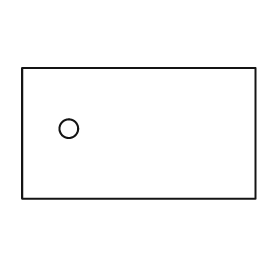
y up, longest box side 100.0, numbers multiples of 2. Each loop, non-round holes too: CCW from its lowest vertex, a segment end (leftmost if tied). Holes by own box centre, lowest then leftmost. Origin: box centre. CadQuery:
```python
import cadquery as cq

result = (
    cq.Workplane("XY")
    .moveTo(-50.0, -28.0)
    .lineTo(50.0, -28.0)
    .lineTo(50.0, 28.0)
    .lineTo(-50.0, 28.0)
    .close()
    .moveTo(-30.0, 2.0)
    .circle(4.0)
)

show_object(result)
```